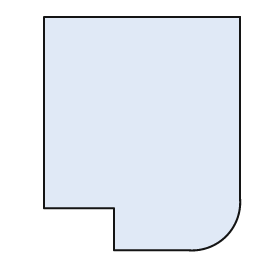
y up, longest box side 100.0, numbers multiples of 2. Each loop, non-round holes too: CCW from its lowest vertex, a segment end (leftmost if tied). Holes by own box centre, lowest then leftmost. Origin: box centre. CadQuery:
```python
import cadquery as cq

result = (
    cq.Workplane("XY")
    .moveTo(-12.0, -50.0)
    .lineTo(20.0, -50.0)
    .threePointArc((36.0, -44.0), (42.0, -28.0))
    .lineTo(42.0, 50.0)
    .lineTo(-42.0, 50.0)
    .lineTo(-42.0, -32.0)
    .lineTo(-12.0, -32.0)
    .close()
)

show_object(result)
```